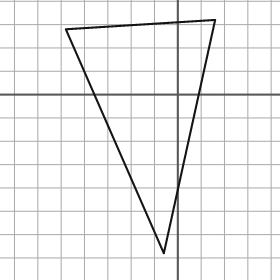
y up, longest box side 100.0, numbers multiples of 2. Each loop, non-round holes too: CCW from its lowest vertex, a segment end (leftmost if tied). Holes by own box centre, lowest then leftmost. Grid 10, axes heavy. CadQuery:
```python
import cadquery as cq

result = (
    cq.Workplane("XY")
    .moveTo(-6.0, -68.0)
    .lineTo(16.0, 32.0)
    .lineTo(-48.0, 28.0)
    .close()
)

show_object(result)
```